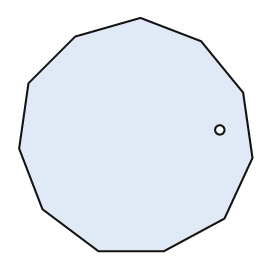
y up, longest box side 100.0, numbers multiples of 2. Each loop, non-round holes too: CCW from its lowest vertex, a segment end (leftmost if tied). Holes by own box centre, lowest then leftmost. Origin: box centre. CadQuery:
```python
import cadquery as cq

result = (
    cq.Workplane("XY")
    .moveTo(-16.0, -50.0)
    .lineTo(12.0, -50.0)
    .lineTo(38.0, -36.0)
    .lineTo(50.0, -10.0)
    .lineTo(46.0, 18.0)
    .lineTo(28.0, 40.0)
    .lineTo(2.0, 50.0)
    .lineTo(-26.0, 42.0)
    .lineTo(-46.0, 22.0)
    .lineTo(-50.0, -6.0)
    .lineTo(-40.0, -32.0)
    .close()
    .moveTo(36.0, 2.0)
    .circle(2.0)
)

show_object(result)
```